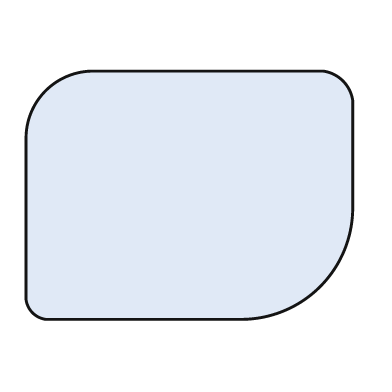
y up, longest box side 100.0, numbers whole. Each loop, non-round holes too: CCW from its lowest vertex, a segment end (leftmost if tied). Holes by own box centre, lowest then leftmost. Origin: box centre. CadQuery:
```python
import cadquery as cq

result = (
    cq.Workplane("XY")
    .moveTo(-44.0, -38.0)
    .lineTo(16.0, -38.0)
    .threePointArc((40.0, -28.0), (50.0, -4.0))
    .lineTo(50.0, 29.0)
    .threePointArc((47.0, 35.0), (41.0, 38.0))
    .lineTo(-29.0, 38.0)
    .threePointArc((-44.0, 32.0), (-50.0, 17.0))
    .lineTo(-50.0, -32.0)
    .threePointArc((-48.0, -36.0), (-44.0, -38.0))
    .close()
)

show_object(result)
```